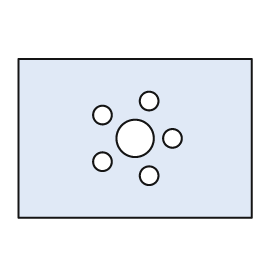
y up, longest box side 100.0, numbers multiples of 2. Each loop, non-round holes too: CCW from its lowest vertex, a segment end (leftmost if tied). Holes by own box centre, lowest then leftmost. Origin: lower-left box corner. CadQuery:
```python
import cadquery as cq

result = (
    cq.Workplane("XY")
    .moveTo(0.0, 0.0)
    .lineTo(100.0, 0.0)
    .lineTo(100.0, 68.0)
    .lineTo(0.0, 68.0)
    .close()
    .moveTo(56.0, 18.0)
    .circle(4.0)
    .moveTo(36.0, 24.0)
    .circle(4.0)
    .moveTo(50.0, 34.0)
    .circle(8.0)
    .moveTo(66.0, 34.0)
    .circle(4.0)
    .moveTo(36.0, 44.0)
    .circle(4.0)
    .moveTo(56.0, 50.0)
    .circle(4.0)
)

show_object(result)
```